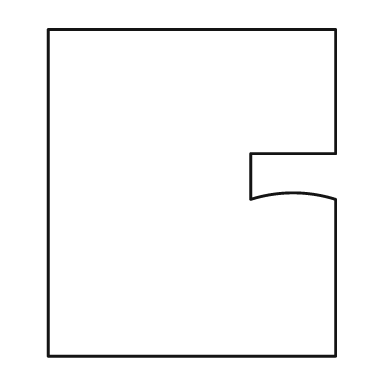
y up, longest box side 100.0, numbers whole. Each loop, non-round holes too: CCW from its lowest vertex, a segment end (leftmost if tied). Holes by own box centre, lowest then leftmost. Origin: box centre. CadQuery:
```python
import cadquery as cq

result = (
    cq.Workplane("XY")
    .moveTo(-44.0, -50.0)
    .lineTo(44.0, -50.0)
    .lineTo(44.0, -2.0)
    .threePointArc((31.0, 0.0), (18.0, -2.0))
    .lineTo(18.0, 12.0)
    .lineTo(44.0, 12.0)
    .lineTo(44.0, 50.0)
    .lineTo(-44.0, 50.0)
    .close()
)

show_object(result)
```